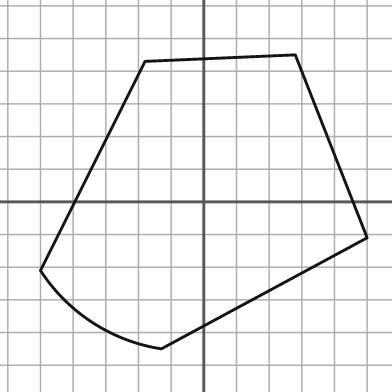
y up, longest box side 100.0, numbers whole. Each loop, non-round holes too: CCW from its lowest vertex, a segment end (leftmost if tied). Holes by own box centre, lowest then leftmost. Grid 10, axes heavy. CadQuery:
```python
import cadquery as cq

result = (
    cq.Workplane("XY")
    .moveTo(-13.0, -45.0)
    .lineTo(50.0, -11.0)
    .lineTo(28.0, 45.0)
    .lineTo(-18.0, 43.0)
    .lineTo(-50.0, -21.0)
    .threePointArc((-34.0, -37.0), (-13.0, -45.0))
    .close()
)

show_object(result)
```